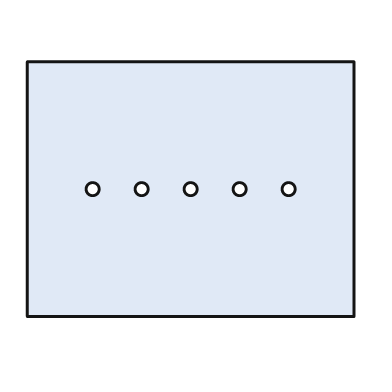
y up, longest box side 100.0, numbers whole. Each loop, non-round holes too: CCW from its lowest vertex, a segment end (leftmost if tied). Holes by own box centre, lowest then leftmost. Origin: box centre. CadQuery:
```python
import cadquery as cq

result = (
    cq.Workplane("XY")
    .moveTo(-50.0, -39.0)
    .lineTo(50.0, -39.0)
    .lineTo(50.0, 39.0)
    .lineTo(-50.0, 39.0)
    .close()
    .moveTo(-30.0, 0.0)
    .circle(2.0)
    .moveTo(-15.0, 0.0)
    .circle(2.0)
    .moveTo(0.0, 0.0)
    .circle(2.0)
    .moveTo(15.0, 0.0)
    .circle(2.0)
    .moveTo(30.0, 0.0)
    .circle(2.0)
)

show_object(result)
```